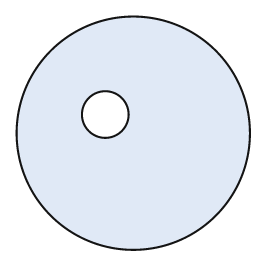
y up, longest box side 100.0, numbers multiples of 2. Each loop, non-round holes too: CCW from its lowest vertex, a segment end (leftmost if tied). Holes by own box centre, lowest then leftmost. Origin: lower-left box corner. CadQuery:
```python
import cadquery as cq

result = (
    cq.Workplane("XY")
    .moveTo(50.0, 50.0)
    .circle(50.0)
    .moveTo(38.0, 58.0)
    .circle(10.0)
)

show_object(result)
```